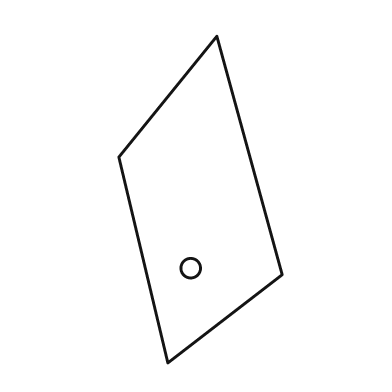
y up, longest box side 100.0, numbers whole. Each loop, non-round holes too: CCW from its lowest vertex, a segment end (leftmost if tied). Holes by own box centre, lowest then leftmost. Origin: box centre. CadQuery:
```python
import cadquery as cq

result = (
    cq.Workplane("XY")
    .moveTo(-10.0, -50.0)
    .lineTo(25.0, -23.0)
    .lineTo(5.0, 50.0)
    .lineTo(-25.0, 13.0)
    .close()
    .moveTo(-3.0, -21.0)
    .circle(3.0)
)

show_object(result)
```